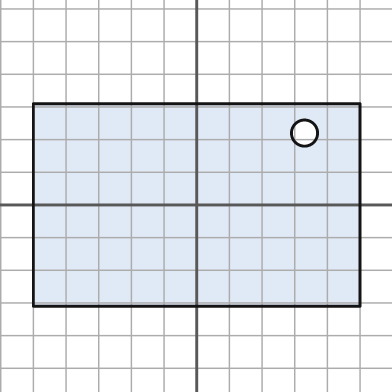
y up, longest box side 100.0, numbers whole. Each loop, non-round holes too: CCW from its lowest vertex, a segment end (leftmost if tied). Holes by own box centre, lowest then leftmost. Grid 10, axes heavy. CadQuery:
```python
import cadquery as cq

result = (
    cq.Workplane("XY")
    .moveTo(-50.0, -31.0)
    .lineTo(50.0, -31.0)
    .lineTo(50.0, 31.0)
    .lineTo(-50.0, 31.0)
    .close()
    .moveTo(33.0, 22.0)
    .circle(4.0)
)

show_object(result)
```